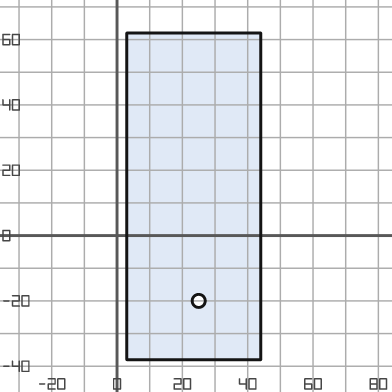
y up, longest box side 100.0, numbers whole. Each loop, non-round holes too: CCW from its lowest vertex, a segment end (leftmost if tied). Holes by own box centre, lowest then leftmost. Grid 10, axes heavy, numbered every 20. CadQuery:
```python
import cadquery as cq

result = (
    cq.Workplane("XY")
    .moveTo(3.0, -38.0)
    .lineTo(44.0, -38.0)
    .lineTo(44.0, 62.0)
    .lineTo(3.0, 62.0)
    .close()
    .moveTo(25.0, -20.0)
    .circle(2.0)
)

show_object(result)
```